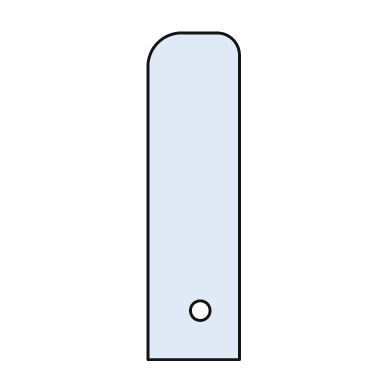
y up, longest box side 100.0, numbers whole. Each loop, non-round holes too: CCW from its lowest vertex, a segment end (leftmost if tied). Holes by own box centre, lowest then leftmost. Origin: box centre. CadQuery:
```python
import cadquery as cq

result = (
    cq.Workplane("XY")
    .moveTo(-14.0, -50.0)
    .lineTo(14.0, -50.0)
    .lineTo(14.0, 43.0)
    .threePointArc((12.0, 48.0), (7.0, 50.0))
    .lineTo(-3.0, 50.0)
    .threePointArc((-11.0, 47.0), (-14.0, 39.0))
    .close()
    .moveTo(2.0, -35.0)
    .circle(3.0)
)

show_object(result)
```